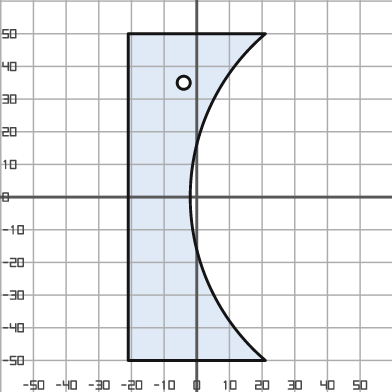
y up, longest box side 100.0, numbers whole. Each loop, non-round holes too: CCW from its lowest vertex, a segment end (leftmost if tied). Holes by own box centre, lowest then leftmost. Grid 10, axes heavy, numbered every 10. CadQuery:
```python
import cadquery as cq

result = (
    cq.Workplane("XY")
    .moveTo(-21.0, -50.0)
    .lineTo(21.0, -50.0)
    .threePointArc((-2.0, 0.0), (21.0, 50.0))
    .lineTo(-21.0, 50.0)
    .close()
    .moveTo(-4.0, 35.0)
    .circle(2.0)
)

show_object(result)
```